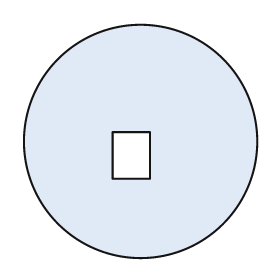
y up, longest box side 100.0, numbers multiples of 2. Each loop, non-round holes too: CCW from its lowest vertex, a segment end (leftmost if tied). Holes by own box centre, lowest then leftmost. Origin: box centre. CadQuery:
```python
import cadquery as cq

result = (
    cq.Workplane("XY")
    .moveTo(0.0, 0.0)
    .circle(50.0)
    .moveTo(-12.0, -16.0)
    .lineTo(4.0, -16.0)
    .lineTo(4.0, 4.0)
    .lineTo(-12.0, 4.0)
    .close()
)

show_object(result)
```